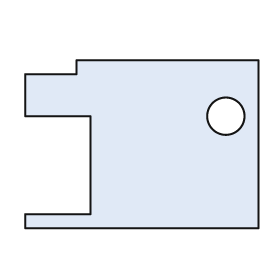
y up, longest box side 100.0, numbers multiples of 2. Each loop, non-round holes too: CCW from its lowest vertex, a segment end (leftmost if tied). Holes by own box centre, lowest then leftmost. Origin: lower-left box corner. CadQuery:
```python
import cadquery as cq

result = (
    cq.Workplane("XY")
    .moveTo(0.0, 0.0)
    .lineTo(100.0, 0.0)
    .lineTo(100.0, 72.0)
    .lineTo(22.0, 72.0)
    .lineTo(22.0, 66.0)
    .lineTo(0.0, 66.0)
    .lineTo(0.0, 48.0)
    .lineTo(28.0, 48.0)
    .lineTo(28.0, 6.0)
    .lineTo(0.0, 6.0)
    .close()
    .moveTo(86.0, 48.0)
    .circle(8.0)
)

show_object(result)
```